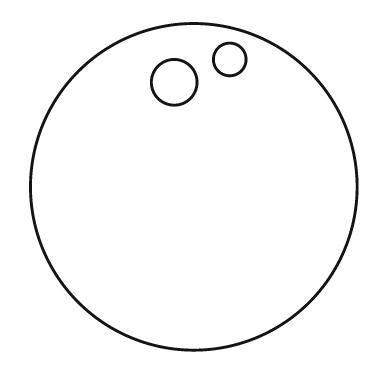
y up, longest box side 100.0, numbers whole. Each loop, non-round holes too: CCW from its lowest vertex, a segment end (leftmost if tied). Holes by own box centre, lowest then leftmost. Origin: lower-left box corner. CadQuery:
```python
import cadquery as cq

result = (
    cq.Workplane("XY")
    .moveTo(50.0, 50.0)
    .circle(50.0)
    .moveTo(44.0, 82.0)
    .circle(7.0)
    .moveTo(61.0, 89.0)
    .circle(5.0)
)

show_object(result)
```